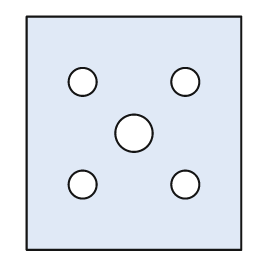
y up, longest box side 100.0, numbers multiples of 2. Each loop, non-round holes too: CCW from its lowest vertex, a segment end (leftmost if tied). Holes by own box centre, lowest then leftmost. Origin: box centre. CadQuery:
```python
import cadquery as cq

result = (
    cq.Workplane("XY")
    .moveTo(-46.0, -50.0)
    .lineTo(46.0, -50.0)
    .lineTo(46.0, 50.0)
    .lineTo(-46.0, 50.0)
    .close()
    .moveTo(-22.0, -22.0)
    .circle(6.0)
    .moveTo(22.0, -22.0)
    .circle(6.0)
    .moveTo(0.0, 0.0)
    .circle(8.0)
    .moveTo(-22.0, 22.0)
    .circle(6.0)
    .moveTo(22.0, 22.0)
    .circle(6.0)
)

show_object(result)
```